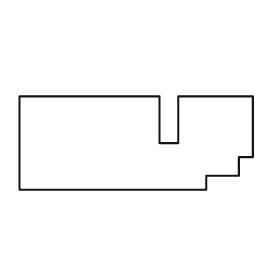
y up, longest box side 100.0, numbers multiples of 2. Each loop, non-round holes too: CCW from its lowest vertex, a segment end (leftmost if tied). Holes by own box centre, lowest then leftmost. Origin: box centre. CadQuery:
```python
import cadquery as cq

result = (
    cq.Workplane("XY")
    .moveTo(-50.0, -20.0)
    .lineTo(30.0, -20.0)
    .lineTo(30.0, -14.0)
    .lineTo(44.0, -14.0)
    .lineTo(44.0, -6.0)
    .lineTo(50.0, -6.0)
    .lineTo(50.0, 20.0)
    .lineTo(18.0, 20.0)
    .lineTo(18.0, 0.0)
    .lineTo(10.0, 0.0)
    .lineTo(10.0, 20.0)
    .lineTo(-50.0, 20.0)
    .close()
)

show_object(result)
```